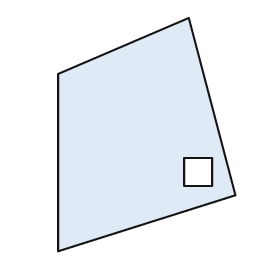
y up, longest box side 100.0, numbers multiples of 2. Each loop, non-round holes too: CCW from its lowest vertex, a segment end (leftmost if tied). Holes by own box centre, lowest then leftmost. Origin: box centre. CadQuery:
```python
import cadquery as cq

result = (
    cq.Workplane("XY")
    .moveTo(-38.0, -50.0)
    .lineTo(38.0, -26.0)
    .lineTo(18.0, 50.0)
    .lineTo(-38.0, 26.0)
    .close()
    .moveTo(16.0, -22.0)
    .lineTo(28.0, -22.0)
    .lineTo(28.0, -10.0)
    .lineTo(16.0, -10.0)
    .close()
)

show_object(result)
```